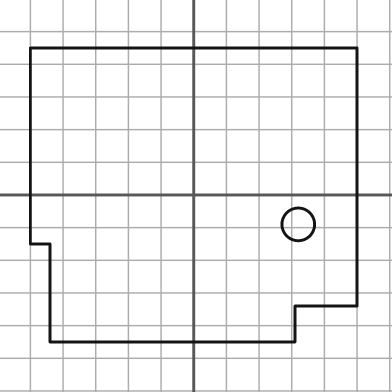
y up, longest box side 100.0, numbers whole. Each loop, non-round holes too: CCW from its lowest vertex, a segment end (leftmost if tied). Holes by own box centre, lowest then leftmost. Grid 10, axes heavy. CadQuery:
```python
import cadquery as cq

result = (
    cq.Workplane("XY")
    .moveTo(-44.0, -45.0)
    .lineTo(31.0, -45.0)
    .lineTo(31.0, -34.0)
    .lineTo(50.0, -34.0)
    .lineTo(50.0, 45.0)
    .lineTo(-50.0, 45.0)
    .lineTo(-50.0, -15.0)
    .lineTo(-44.0, -15.0)
    .close()
    .moveTo(32.0, -9.0)
    .circle(5.0)
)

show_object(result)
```